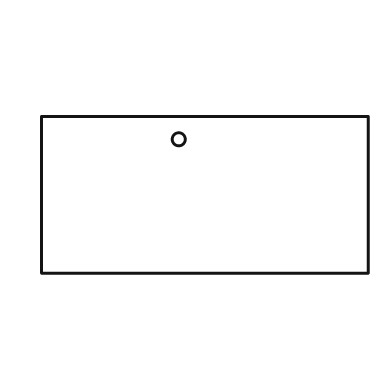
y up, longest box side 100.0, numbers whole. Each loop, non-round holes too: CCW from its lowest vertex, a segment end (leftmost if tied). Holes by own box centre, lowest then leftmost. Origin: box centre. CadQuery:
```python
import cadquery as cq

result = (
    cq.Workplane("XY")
    .moveTo(-50.0, -24.0)
    .lineTo(50.0, -24.0)
    .lineTo(50.0, 24.0)
    .lineTo(-50.0, 24.0)
    .close()
    .moveTo(-8.0, 17.0)
    .circle(2.0)
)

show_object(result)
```